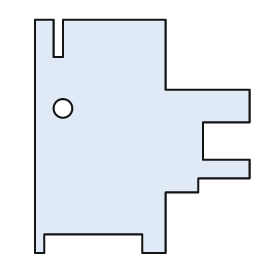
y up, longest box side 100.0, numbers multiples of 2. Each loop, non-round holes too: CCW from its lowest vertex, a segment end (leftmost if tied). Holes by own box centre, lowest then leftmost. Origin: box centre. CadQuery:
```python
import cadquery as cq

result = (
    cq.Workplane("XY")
    .moveTo(-46.0, -50.0)
    .lineTo(-42.0, -50.0)
    .lineTo(-42.0, -42.0)
    .lineTo(0.0, -42.0)
    .lineTo(0.0, -50.0)
    .lineTo(10.0, -50.0)
    .lineTo(10.0, -24.0)
    .lineTo(24.0, -24.0)
    .lineTo(24.0, -18.0)
    .lineTo(46.0, -18.0)
    .lineTo(46.0, -10.0)
    .lineTo(26.0, -10.0)
    .lineTo(26.0, 6.0)
    .lineTo(46.0, 6.0)
    .lineTo(46.0, 20.0)
    .lineTo(10.0, 20.0)
    .lineTo(10.0, 50.0)
    .lineTo(-34.0, 50.0)
    .lineTo(-34.0, 34.0)
    .lineTo(-38.0, 34.0)
    .lineTo(-38.0, 50.0)
    .lineTo(-46.0, 50.0)
    .close()
    .moveTo(-34.0, 12.0)
    .circle(4.0)
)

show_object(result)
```